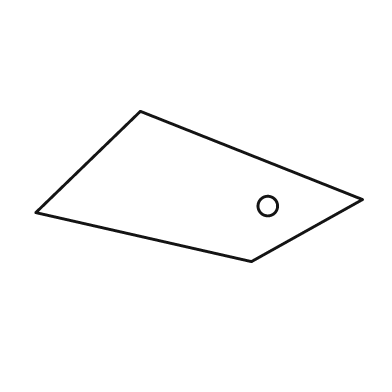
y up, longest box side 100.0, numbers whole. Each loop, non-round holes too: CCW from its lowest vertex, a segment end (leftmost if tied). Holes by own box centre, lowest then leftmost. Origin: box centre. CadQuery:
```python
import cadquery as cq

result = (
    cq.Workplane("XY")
    .moveTo(16.0, -23.0)
    .lineTo(50.0, -4.0)
    .lineTo(-18.0, 23.0)
    .lineTo(-50.0, -8.0)
    .close()
    .moveTo(21.0, -6.0)
    .circle(3.0)
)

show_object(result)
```